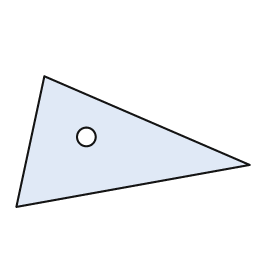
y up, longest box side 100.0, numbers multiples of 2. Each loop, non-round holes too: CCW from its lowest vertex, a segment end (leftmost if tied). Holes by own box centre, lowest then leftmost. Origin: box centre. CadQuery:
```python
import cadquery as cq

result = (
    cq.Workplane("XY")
    .moveTo(-50.0, -28.0)
    .lineTo(50.0, -10.0)
    .lineTo(-38.0, 28.0)
    .close()
    .moveTo(-20.0, 2.0)
    .circle(4.0)
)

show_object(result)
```